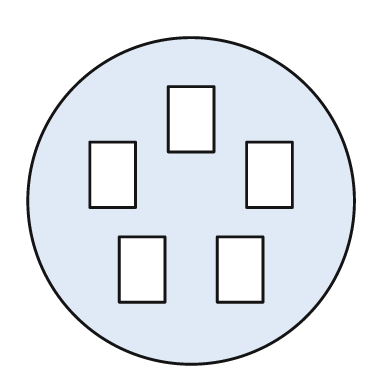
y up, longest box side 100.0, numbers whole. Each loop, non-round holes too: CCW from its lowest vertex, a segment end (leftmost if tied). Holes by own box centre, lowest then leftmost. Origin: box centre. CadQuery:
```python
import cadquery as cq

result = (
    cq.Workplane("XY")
    .moveTo(0.0, 0.0)
    .circle(50.0)
    .moveTo(-22.0, -31.0)
    .lineTo(-8.0, -31.0)
    .lineTo(-8.0, -11.0)
    .lineTo(-22.0, -11.0)
    .close()
    .moveTo(8.0, -31.0)
    .lineTo(22.0, -31.0)
    .lineTo(22.0, -11.0)
    .lineTo(8.0, -11.0)
    .close()
    .moveTo(-31.0, -2.0)
    .lineTo(-17.0, -2.0)
    .lineTo(-17.0, 18.0)
    .lineTo(-31.0, 18.0)
    .close()
    .moveTo(17.0, -2.0)
    .lineTo(31.0, -2.0)
    .lineTo(31.0, 18.0)
    .lineTo(17.0, 18.0)
    .close()
    .moveTo(-7.0, 15.0)
    .lineTo(7.0, 15.0)
    .lineTo(7.0, 35.0)
    .lineTo(-7.0, 35.0)
    .close()
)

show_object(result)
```